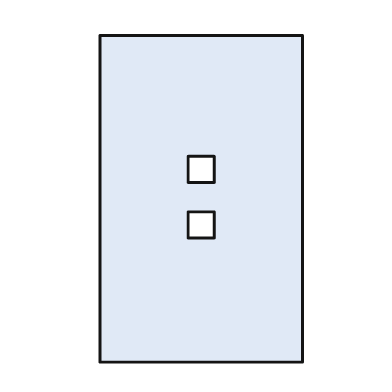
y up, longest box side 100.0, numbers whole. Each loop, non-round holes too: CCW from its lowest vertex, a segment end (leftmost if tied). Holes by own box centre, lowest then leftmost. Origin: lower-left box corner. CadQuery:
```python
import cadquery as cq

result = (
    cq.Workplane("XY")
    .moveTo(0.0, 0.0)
    .lineTo(62.0, 0.0)
    .lineTo(62.0, 100.0)
    .lineTo(0.0, 100.0)
    .close()
    .moveTo(27.0, 38.0)
    .lineTo(35.0, 38.0)
    .lineTo(35.0, 46.0)
    .lineTo(27.0, 46.0)
    .close()
    .moveTo(27.0, 55.0)
    .lineTo(35.0, 55.0)
    .lineTo(35.0, 63.0)
    .lineTo(27.0, 63.0)
    .close()
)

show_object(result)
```